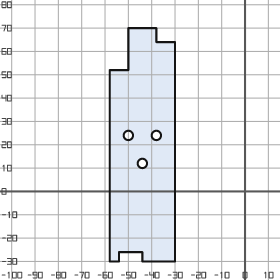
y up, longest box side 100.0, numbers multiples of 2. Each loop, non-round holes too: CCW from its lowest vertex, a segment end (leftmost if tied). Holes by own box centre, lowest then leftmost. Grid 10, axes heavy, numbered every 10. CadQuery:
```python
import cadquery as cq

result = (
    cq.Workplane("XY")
    .moveTo(-58.0, -30.0)
    .lineTo(-54.0, -30.0)
    .lineTo(-54.0, -26.0)
    .lineTo(-44.0, -26.0)
    .lineTo(-44.0, -30.0)
    .lineTo(-30.0, -30.0)
    .lineTo(-30.0, 64.0)
    .lineTo(-38.0, 64.0)
    .lineTo(-38.0, 70.0)
    .lineTo(-50.0, 70.0)
    .lineTo(-50.0, 52.0)
    .lineTo(-58.0, 52.0)
    .close()
    .moveTo(-44.0, 12.0)
    .circle(2.0)
    .moveTo(-50.0, 24.0)
    .circle(2.0)
    .moveTo(-38.0, 24.0)
    .circle(2.0)
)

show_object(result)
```